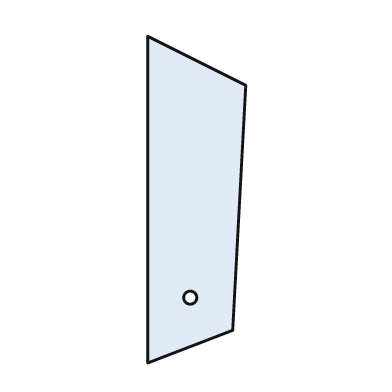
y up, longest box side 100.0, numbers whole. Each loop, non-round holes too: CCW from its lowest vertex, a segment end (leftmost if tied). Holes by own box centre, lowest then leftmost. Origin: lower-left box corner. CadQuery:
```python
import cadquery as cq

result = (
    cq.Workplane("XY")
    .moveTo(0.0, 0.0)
    .lineTo(26.0, 10.0)
    .lineTo(30.0, 85.0)
    .lineTo(0.0, 100.0)
    .close()
    .moveTo(13.0, 20.0)
    .circle(2.0)
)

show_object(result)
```